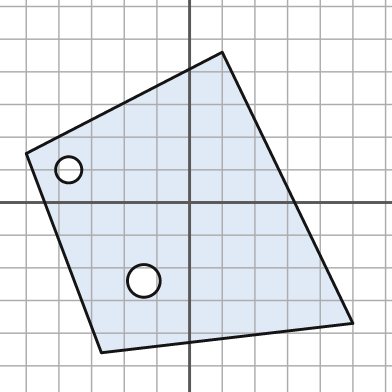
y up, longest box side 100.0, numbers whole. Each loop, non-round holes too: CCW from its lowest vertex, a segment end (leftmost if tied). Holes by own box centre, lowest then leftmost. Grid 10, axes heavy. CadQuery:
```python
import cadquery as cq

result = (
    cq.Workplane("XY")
    .moveTo(-27.0, -46.0)
    .lineTo(50.0, -37.0)
    .lineTo(10.0, 46.0)
    .lineTo(-50.0, 15.0)
    .close()
    .moveTo(-14.0, -24.0)
    .circle(5.0)
    .moveTo(-37.0, 10.0)
    .circle(4.0)
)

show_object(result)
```